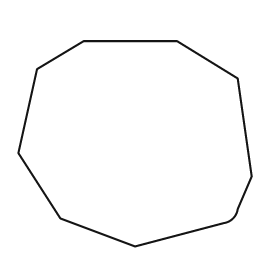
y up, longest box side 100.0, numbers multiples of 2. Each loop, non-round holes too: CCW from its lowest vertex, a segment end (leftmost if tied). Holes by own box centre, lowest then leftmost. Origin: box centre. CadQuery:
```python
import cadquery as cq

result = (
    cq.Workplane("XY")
    .moveTo(0.0, -44.0)
    .lineTo(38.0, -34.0)
    .threePointArc((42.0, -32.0), (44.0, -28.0))
    .lineTo(50.0, -14.0)
    .lineTo(44.0, 28.0)
    .lineTo(18.0, 44.0)
    .lineTo(-22.0, 44.0)
    .lineTo(-42.0, 32.0)
    .lineTo(-50.0, -4.0)
    .lineTo(-32.0, -32.0)
    .close()
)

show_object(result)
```